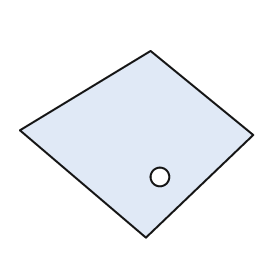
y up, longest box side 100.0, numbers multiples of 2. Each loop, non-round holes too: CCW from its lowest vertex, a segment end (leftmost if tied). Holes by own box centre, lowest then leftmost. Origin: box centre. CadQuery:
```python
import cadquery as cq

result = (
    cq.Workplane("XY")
    .moveTo(4.0, -40.0)
    .lineTo(50.0, 4.0)
    .lineTo(6.0, 40.0)
    .lineTo(-50.0, 6.0)
    .close()
    .moveTo(10.0, -14.0)
    .circle(4.0)
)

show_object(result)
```